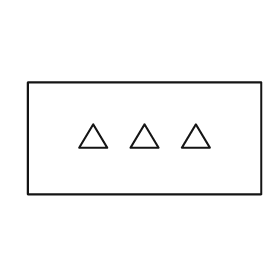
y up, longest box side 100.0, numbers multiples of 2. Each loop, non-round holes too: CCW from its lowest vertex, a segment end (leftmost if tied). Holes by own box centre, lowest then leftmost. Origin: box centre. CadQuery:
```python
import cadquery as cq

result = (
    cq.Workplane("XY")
    .moveTo(-50.0, -24.0)
    .lineTo(50.0, -24.0)
    .lineTo(50.0, 24.0)
    .lineTo(-50.0, 24.0)
    .close()
    .moveTo(-28.0, -4.0)
    .lineTo(-16.0, -4.0)
    .lineTo(-22.0, 6.0)
    .close()
    .moveTo(-6.0, -4.0)
    .lineTo(6.0, -4.0)
    .lineTo(0.0, 6.0)
    .close()
    .moveTo(16.0, -4.0)
    .lineTo(28.0, -4.0)
    .lineTo(22.0, 6.0)
    .close()
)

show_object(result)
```